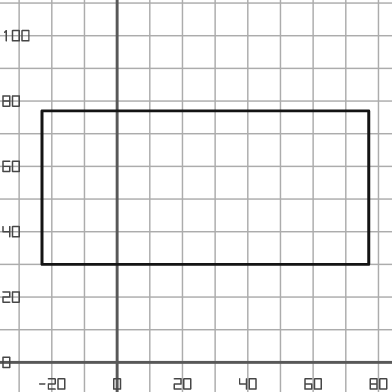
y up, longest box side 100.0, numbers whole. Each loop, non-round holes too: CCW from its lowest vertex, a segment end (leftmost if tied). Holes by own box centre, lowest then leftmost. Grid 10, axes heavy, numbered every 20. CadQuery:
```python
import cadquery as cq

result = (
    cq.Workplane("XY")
    .moveTo(-23.0, 30.0)
    .lineTo(77.0, 30.0)
    .lineTo(77.0, 77.0)
    .lineTo(-23.0, 77.0)
    .close()
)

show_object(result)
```